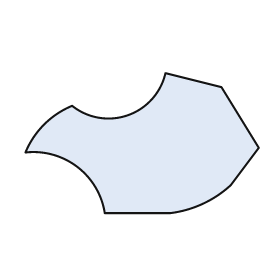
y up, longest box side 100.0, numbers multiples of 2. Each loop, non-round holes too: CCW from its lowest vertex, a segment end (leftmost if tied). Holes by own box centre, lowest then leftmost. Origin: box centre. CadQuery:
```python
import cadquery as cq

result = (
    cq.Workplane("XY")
    .moveTo(-16.0, -30.0)
    .lineTo(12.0, -30.0)
    .threePointArc((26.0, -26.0), (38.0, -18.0))
    .lineTo(50.0, -2.0)
    .lineTo(34.0, 24.0)
    .lineTo(10.0, 30.0)
    .threePointArc((-6.0, 12.0), (-30.0, 16.0))
    .threePointArc((-42.0, 8.0), (-50.0, -4.0))
    .threePointArc((-28.0, -10.0), (-16.0, -30.0))
    .close()
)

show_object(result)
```